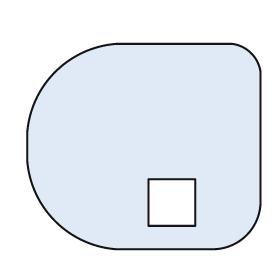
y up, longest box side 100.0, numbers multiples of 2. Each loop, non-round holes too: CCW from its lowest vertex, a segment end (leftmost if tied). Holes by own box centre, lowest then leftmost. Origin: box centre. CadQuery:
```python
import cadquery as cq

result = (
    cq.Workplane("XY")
    .moveTo(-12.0, -44.0)
    .lineTo(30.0, -44.0)
    .threePointArc((44.0, -38.0), (50.0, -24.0))
    .lineTo(50.0, 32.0)
    .threePointArc((46.0, 40.0), (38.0, 44.0))
    .lineTo(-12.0, 44.0)
    .threePointArc((-38.0, 32.0), (-50.0, 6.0))
    .lineTo(-50.0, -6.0)
    .threePointArc((-38.0, -32.0), (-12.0, -44.0))
    .close()
    .moveTo(2.0, -34.0)
    .lineTo(22.0, -34.0)
    .lineTo(22.0, -14.0)
    .lineTo(2.0, -14.0)
    .close()
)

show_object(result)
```